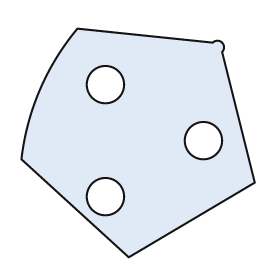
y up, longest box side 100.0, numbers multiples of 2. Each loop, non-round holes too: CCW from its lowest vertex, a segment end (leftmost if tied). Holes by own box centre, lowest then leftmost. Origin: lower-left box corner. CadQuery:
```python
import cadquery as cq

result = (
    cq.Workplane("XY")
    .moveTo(46.0, 0.0)
    .lineTo(100.0, 32.0)
    .lineTo(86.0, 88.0)
    .threePointArc((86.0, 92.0), (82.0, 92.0))
    .lineTo(24.0, 98.0)
    .threePointArc((8.0, 72.0), (0.0, 42.0))
    .close()
    .moveTo(36.0, 26.0)
    .circle(8.0)
    .moveTo(78.0, 50.0)
    .circle(8.0)
    .moveTo(36.0, 74.0)
    .circle(8.0)
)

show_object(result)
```